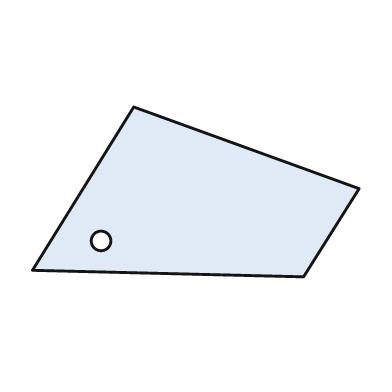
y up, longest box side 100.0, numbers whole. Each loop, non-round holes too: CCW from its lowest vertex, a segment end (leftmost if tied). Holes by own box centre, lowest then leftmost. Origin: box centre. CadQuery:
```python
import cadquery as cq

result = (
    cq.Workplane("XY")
    .moveTo(33.0, -26.0)
    .lineTo(50.0, 1.0)
    .lineTo(-19.0, 26.0)
    .lineTo(-50.0, -24.0)
    .close()
    .moveTo(-29.0, -15.0)
    .circle(3.0)
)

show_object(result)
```